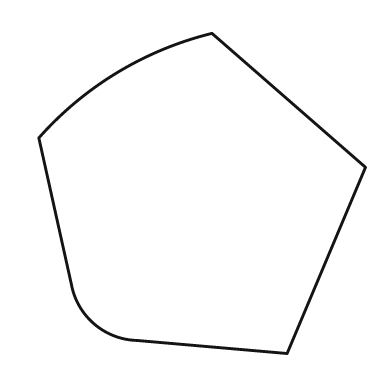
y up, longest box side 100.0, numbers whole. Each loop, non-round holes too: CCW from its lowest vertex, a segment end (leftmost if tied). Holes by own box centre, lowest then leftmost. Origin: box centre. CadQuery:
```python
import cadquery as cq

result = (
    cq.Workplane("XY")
    .moveTo(26.0, -49.0)
    .lineTo(50.0, 8.0)
    .lineTo(3.0, 49.0)
    .threePointArc((-26.0, 37.0), (-50.0, 17.0))
    .lineTo(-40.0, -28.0)
    .threePointArc((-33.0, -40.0), (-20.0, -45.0))
    .close()
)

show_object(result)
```